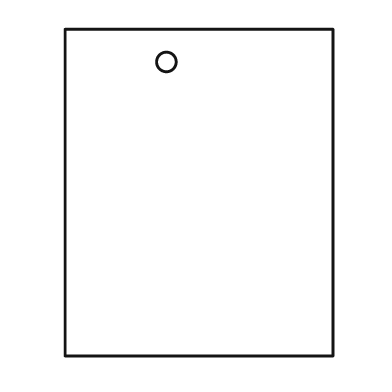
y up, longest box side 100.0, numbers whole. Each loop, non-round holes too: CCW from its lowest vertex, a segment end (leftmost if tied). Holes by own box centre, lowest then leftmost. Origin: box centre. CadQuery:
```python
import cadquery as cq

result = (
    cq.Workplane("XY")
    .moveTo(-41.0, -50.0)
    .lineTo(41.0, -50.0)
    .lineTo(41.0, 50.0)
    .lineTo(-41.0, 50.0)
    .close()
    .moveTo(-10.0, 40.0)
    .circle(3.0)
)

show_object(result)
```